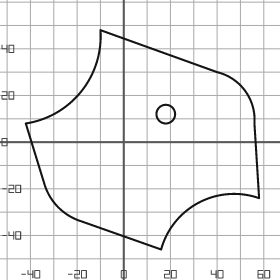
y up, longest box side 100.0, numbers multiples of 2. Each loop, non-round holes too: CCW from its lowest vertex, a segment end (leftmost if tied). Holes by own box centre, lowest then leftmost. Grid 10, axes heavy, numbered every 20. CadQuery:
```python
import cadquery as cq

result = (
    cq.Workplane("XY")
    .moveTo(16.0, -46.0)
    .threePointArc((32.0, -26.0), (58.0, -24.0))
    .lineTo(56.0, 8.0)
    .threePointArc((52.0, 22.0), (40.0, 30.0))
    .lineTo(-10.0, 48.0)
    .threePointArc((-18.0, 22.0), (-42.0, 8.0))
    .lineTo(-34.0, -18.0)
    .threePointArc((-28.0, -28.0), (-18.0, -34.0))
    .close()
    .moveTo(18.0, 12.0)
    .circle(4.0)
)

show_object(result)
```